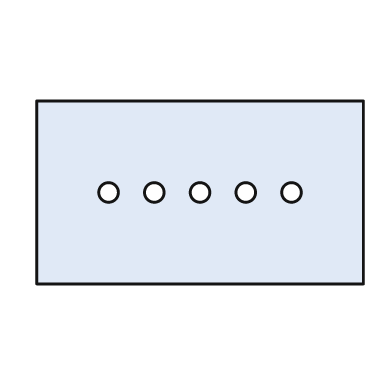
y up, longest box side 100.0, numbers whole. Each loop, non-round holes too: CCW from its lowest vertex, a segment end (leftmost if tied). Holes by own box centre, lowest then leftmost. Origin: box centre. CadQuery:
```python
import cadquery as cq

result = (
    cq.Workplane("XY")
    .moveTo(-50.0, -28.0)
    .lineTo(50.0, -28.0)
    .lineTo(50.0, 28.0)
    .lineTo(-50.0, 28.0)
    .close()
    .moveTo(-28.0, 0.0)
    .circle(3.0)
    .moveTo(-14.0, 0.0)
    .circle(3.0)
    .moveTo(0.0, 0.0)
    .circle(3.0)
    .moveTo(14.0, 0.0)
    .circle(3.0)
    .moveTo(28.0, 0.0)
    .circle(3.0)
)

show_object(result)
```